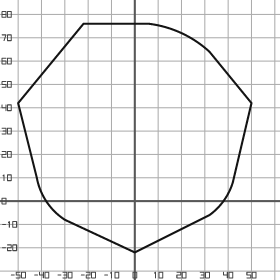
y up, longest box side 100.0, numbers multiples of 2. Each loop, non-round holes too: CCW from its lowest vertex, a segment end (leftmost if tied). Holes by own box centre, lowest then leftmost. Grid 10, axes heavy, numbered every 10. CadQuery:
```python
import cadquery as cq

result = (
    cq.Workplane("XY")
    .moveTo(0.0, -22.0)
    .lineTo(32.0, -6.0)
    .threePointArc((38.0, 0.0), (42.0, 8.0))
    .lineTo(50.0, 42.0)
    .lineTo(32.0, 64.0)
    .threePointArc((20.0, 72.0), (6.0, 76.0))
    .lineTo(-22.0, 76.0)
    .lineTo(-50.0, 42.0)
    .lineTo(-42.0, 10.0)
    .threePointArc((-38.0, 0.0), (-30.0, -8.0))
    .close()
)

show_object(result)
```